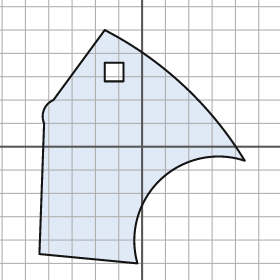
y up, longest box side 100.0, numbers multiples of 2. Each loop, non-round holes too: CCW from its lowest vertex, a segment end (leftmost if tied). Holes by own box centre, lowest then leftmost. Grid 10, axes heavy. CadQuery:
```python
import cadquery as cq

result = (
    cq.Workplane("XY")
    .moveTo(-2.0, -50.0)
    .threePointArc((8.0, -14.0), (44.0, -6.0))
    .threePointArc((18.0, 26.0), (-16.0, 50.0))
    .lineTo(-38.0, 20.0)
    .threePointArc((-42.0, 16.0), (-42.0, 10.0))
    .lineTo(-44.0, -46.0)
    .close()
    .moveTo(-16.0, 28.0)
    .lineTo(-8.0, 28.0)
    .lineTo(-8.0, 36.0)
    .lineTo(-16.0, 36.0)
    .close()
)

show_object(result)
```